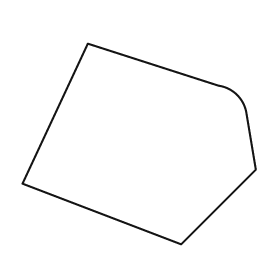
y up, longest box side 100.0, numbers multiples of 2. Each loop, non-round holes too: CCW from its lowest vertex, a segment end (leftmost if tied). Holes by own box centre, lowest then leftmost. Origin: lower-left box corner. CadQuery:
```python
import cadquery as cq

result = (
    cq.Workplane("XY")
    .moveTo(68.0, 0.0)
    .lineTo(100.0, 32.0)
    .lineTo(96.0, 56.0)
    .threePointArc((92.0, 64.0), (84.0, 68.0))
    .lineTo(28.0, 86.0)
    .lineTo(0.0, 26.0)
    .close()
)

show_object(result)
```